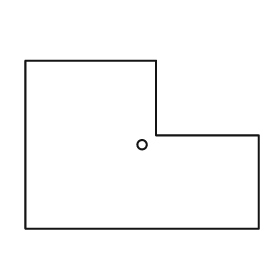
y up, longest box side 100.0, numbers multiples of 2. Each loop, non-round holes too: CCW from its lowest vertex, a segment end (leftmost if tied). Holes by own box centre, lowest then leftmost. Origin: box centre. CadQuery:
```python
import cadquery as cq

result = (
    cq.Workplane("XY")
    .moveTo(-50.0, -36.0)
    .lineTo(50.0, -36.0)
    .lineTo(50.0, 4.0)
    .lineTo(6.0, 4.0)
    .lineTo(6.0, 36.0)
    .lineTo(-50.0, 36.0)
    .close()
    .moveTo(0.0, 0.0)
    .circle(2.0)
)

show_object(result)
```